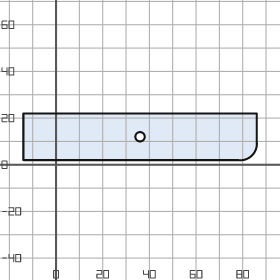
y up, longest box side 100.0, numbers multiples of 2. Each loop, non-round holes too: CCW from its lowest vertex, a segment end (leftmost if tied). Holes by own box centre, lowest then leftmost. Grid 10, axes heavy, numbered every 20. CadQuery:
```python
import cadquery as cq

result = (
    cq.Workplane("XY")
    .moveTo(-14.0, 2.0)
    .lineTo(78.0, 2.0)
    .threePointArc((84.0, 4.0), (86.0, 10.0))
    .lineTo(86.0, 22.0)
    .lineTo(-14.0, 22.0)
    .close()
    .moveTo(36.0, 12.0)
    .circle(2.0)
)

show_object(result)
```